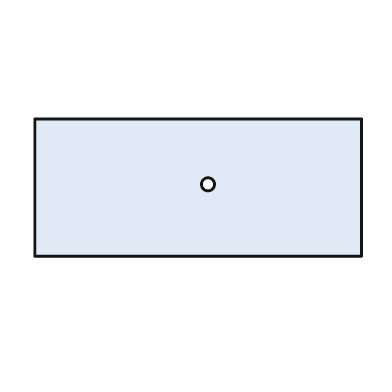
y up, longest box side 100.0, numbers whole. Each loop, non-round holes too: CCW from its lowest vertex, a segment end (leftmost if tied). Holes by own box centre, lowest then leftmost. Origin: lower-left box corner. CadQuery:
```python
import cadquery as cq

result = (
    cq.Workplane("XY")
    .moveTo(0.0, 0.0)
    .lineTo(100.0, 0.0)
    .lineTo(100.0, 42.0)
    .lineTo(0.0, 42.0)
    .close()
    .moveTo(53.0, 22.0)
    .circle(2.0)
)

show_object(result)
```